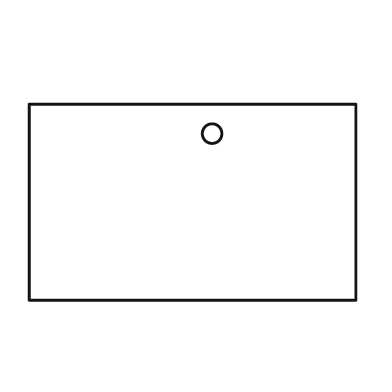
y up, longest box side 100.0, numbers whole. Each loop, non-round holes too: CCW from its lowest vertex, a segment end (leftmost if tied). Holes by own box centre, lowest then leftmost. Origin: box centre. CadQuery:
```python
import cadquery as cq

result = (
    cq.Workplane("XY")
    .moveTo(-50.0, -30.0)
    .lineTo(50.0, -30.0)
    .lineTo(50.0, 30.0)
    .lineTo(-50.0, 30.0)
    .close()
    .moveTo(6.0, 21.0)
    .circle(3.0)
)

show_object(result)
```